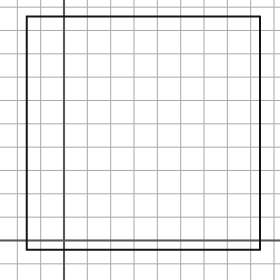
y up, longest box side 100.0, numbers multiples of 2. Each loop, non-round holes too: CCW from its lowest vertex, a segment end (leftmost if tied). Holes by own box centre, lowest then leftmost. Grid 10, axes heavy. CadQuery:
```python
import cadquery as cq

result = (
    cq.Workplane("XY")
    .moveTo(-16.0, -4.0)
    .lineTo(84.0, -4.0)
    .lineTo(84.0, 96.0)
    .lineTo(-16.0, 96.0)
    .close()
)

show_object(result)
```